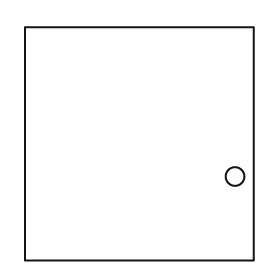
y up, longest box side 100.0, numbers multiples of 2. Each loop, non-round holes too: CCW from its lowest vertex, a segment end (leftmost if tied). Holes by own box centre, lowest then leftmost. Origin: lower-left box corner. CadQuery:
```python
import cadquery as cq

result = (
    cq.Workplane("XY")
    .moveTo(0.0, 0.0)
    .lineTo(98.0, 0.0)
    .lineTo(98.0, 100.0)
    .lineTo(0.0, 100.0)
    .close()
    .moveTo(90.0, 36.0)
    .circle(4.0)
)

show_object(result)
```